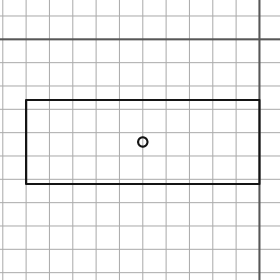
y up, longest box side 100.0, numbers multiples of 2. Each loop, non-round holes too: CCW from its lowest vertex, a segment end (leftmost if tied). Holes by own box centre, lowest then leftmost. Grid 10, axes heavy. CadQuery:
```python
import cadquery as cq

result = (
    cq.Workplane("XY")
    .moveTo(-100.0, -62.0)
    .lineTo(0.0, -62.0)
    .lineTo(0.0, -26.0)
    .lineTo(-100.0, -26.0)
    .close()
    .moveTo(-50.0, -44.0)
    .circle(2.0)
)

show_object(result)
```